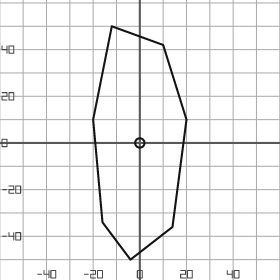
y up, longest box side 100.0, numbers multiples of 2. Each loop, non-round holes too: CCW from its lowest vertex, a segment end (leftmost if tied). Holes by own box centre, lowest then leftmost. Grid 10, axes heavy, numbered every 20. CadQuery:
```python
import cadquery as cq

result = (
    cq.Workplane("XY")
    .moveTo(-4.0, -50.0)
    .lineTo(14.0, -36.0)
    .lineTo(20.0, 10.0)
    .lineTo(10.0, 42.0)
    .lineTo(-12.0, 50.0)
    .lineTo(-20.0, 10.0)
    .lineTo(-16.0, -34.0)
    .close()
    .moveTo(0.0, 0.0)
    .circle(2.0)
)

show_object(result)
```